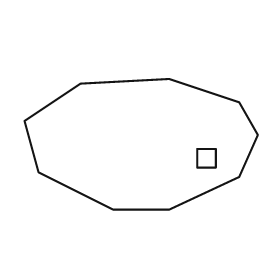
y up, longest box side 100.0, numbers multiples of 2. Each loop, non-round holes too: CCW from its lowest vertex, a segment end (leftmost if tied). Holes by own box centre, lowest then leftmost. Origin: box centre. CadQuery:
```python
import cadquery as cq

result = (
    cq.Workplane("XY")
    .moveTo(-12.0, -28.0)
    .lineTo(12.0, -28.0)
    .lineTo(42.0, -14.0)
    .lineTo(50.0, 4.0)
    .lineTo(42.0, 18.0)
    .lineTo(12.0, 28.0)
    .lineTo(-26.0, 26.0)
    .lineTo(-50.0, 10.0)
    .lineTo(-44.0, -12.0)
    .close()
    .moveTo(24.0, -10.0)
    .lineTo(32.0, -10.0)
    .lineTo(32.0, -2.0)
    .lineTo(24.0, -2.0)
    .close()
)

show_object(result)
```